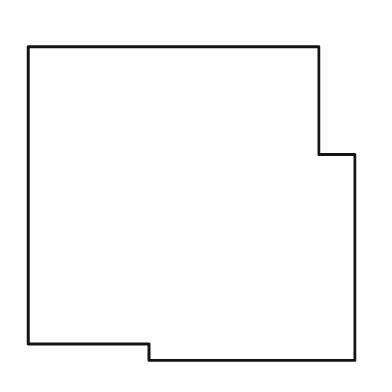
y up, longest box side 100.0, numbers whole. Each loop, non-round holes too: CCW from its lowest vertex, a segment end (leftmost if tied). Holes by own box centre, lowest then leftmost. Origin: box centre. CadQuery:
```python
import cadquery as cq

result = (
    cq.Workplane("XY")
    .moveTo(-13.0, -48.0)
    .lineTo(50.0, -48.0)
    .lineTo(50.0, 15.0)
    .lineTo(39.0, 15.0)
    .lineTo(39.0, 48.0)
    .lineTo(-50.0, 48.0)
    .lineTo(-50.0, -43.0)
    .lineTo(-13.0, -43.0)
    .close()
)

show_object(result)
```